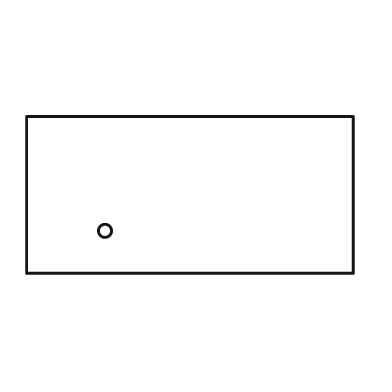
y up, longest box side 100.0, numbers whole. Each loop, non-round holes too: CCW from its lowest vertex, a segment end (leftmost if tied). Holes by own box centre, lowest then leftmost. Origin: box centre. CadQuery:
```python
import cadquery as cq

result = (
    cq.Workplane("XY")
    .moveTo(-50.0, -24.0)
    .lineTo(50.0, -24.0)
    .lineTo(50.0, 24.0)
    .lineTo(-50.0, 24.0)
    .close()
    .moveTo(-26.0, -11.0)
    .circle(2.0)
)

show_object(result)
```